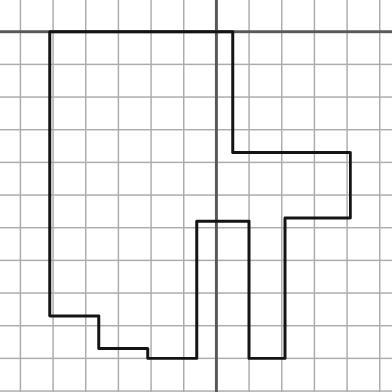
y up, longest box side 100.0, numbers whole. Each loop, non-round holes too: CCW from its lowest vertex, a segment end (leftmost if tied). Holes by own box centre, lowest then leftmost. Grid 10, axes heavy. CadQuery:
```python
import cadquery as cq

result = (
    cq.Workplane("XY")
    .moveTo(-21.0, -100.0)
    .lineTo(-6.0, -100.0)
    .lineTo(-6.0, -58.0)
    .lineTo(10.0, -58.0)
    .lineTo(10.0, -100.0)
    .lineTo(21.0, -100.0)
    .lineTo(21.0, -57.0)
    .lineTo(41.0, -57.0)
    .lineTo(41.0, -37.0)
    .lineTo(5.0, -37.0)
    .lineTo(5.0, 0.0)
    .lineTo(-51.0, 0.0)
    .lineTo(-51.0, -87.0)
    .lineTo(-36.0, -87.0)
    .lineTo(-36.0, -97.0)
    .lineTo(-21.0, -97.0)
    .close()
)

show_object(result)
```